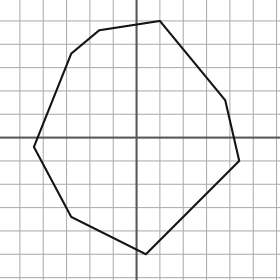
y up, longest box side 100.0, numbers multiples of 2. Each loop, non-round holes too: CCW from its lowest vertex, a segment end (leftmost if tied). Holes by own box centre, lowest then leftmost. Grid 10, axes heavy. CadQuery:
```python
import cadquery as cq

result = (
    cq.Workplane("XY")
    .moveTo(4.0, -50.0)
    .lineTo(44.0, -10.0)
    .lineTo(38.0, 16.0)
    .lineTo(10.0, 50.0)
    .lineTo(-16.0, 46.0)
    .lineTo(-28.0, 36.0)
    .lineTo(-44.0, -4.0)
    .lineTo(-28.0, -34.0)
    .close()
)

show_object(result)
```